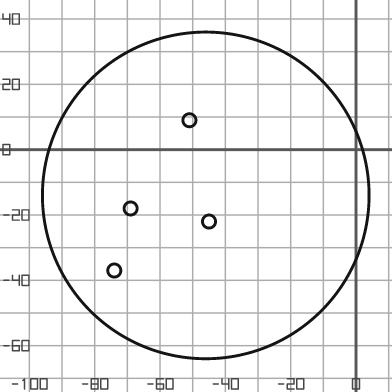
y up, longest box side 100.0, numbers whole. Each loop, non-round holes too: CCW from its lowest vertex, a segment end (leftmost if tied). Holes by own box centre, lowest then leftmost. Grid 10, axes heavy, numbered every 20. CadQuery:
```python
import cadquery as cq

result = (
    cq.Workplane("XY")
    .moveTo(-46.0, -14.0)
    .circle(50.0)
    .moveTo(-74.0, -37.0)
    .circle(2.0)
    .moveTo(-45.0, -22.0)
    .circle(2.0)
    .moveTo(-69.0, -18.0)
    .circle(2.0)
    .moveTo(-51.0, 9.0)
    .circle(2.0)
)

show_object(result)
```